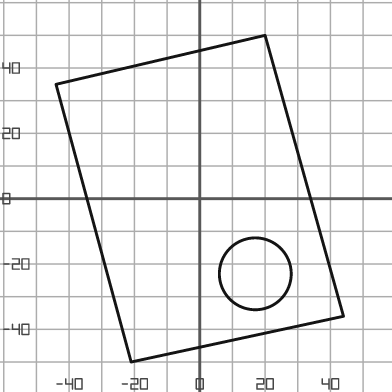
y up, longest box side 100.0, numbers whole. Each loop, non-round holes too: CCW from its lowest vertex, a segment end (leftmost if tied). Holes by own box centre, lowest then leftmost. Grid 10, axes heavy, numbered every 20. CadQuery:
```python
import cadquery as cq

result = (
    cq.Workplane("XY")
    .moveTo(-21.0, -50.0)
    .lineTo(44.0, -36.0)
    .lineTo(20.0, 50.0)
    .lineTo(-44.0, 35.0)
    .close()
    .moveTo(17.0, -23.0)
    .circle(11.0)
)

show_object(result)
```